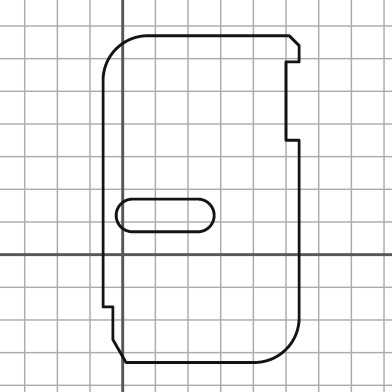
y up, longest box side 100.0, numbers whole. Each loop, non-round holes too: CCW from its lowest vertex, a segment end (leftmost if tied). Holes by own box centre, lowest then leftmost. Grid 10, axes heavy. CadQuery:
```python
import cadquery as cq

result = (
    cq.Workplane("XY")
    .moveTo(1.0, -33.0)
    .lineTo(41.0, -33.0)
    .threePointArc((50.0, -29.0), (54.0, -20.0))
    .lineTo(54.0, 35.0)
    .lineTo(50.0, 35.0)
    .lineTo(50.0, 59.0)
    .lineTo(54.0, 59.0)
    .lineTo(54.0, 64.0)
    .lineTo(51.0, 67.0)
    .lineTo(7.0, 67.0)
    .threePointArc((-2.0, 63.0), (-6.0, 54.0))
    .lineTo(-6.0, -16.0)
    .lineTo(-3.0, -16.0)
    .lineTo(-3.0, -26.0)
    .close()
    .moveTo(3.0, 7.0)
    .lineTo(23.0, 7.0)
    .threePointArc((28.0, 12.0), (23.0, 17.0))
    .lineTo(3.0, 17.0)
    .threePointArc((-2.0, 12.0), (3.0, 7.0))
    .close()
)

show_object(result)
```